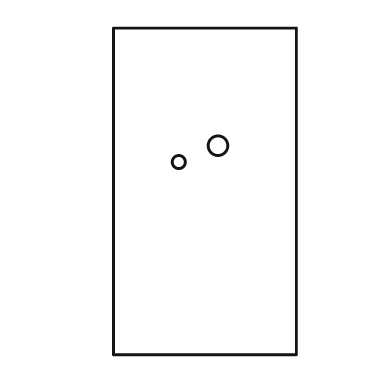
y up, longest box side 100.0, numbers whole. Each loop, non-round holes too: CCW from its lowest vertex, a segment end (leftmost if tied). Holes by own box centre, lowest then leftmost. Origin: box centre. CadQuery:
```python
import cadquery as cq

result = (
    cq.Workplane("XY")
    .moveTo(-28.0, -50.0)
    .lineTo(28.0, -50.0)
    .lineTo(28.0, 50.0)
    .lineTo(-28.0, 50.0)
    .close()
    .moveTo(-8.0, 9.0)
    .circle(2.0)
    .moveTo(4.0, 14.0)
    .circle(3.0)
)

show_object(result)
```